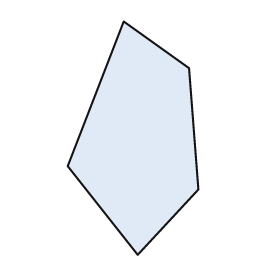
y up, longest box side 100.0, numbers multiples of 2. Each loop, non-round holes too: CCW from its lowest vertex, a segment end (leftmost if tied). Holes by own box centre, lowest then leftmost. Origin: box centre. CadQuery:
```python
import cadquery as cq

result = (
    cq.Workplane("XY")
    .moveTo(2.0, -50.0)
    .lineTo(28.0, -22.0)
    .lineTo(24.0, 30.0)
    .lineTo(-4.0, 50.0)
    .lineTo(-28.0, -12.0)
    .close()
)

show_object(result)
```